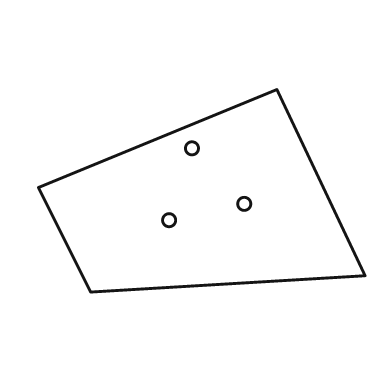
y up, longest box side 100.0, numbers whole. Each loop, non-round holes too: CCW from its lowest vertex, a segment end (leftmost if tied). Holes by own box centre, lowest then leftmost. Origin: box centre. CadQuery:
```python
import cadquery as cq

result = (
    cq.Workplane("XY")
    .moveTo(-34.0, -31.0)
    .lineTo(50.0, -26.0)
    .lineTo(23.0, 31.0)
    .lineTo(-50.0, 1.0)
    .close()
    .moveTo(-10.0, -9.0)
    .circle(2.0)
    .moveTo(13.0, -4.0)
    .circle(2.0)
    .moveTo(-3.0, 13.0)
    .circle(2.0)
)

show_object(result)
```